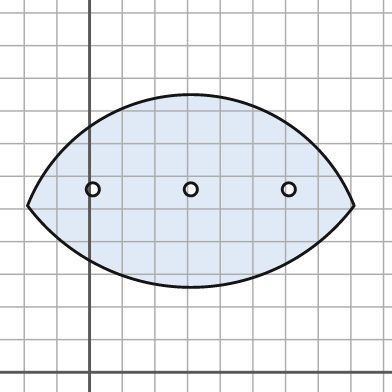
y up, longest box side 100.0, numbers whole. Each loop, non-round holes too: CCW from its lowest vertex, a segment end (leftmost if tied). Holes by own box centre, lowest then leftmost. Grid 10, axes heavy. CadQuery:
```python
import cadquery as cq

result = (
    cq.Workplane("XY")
    .moveTo(-19.0, 51.0)
    .threePointArc((31.0, 26.0), (81.0, 51.0))
    .threePointArc((31.0, 85.0), (-19.0, 51.0))
    .close()
    .moveTo(1.0, 56.0)
    .circle(2.0)
    .moveTo(31.0, 56.0)
    .circle(2.0)
    .moveTo(61.0, 56.0)
    .circle(2.0)
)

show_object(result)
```